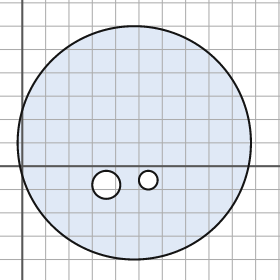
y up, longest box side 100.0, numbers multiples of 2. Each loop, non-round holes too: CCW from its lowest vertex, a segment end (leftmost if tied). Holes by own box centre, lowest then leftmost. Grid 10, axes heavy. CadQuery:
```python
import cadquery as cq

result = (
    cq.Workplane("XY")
    .moveTo(48.0, 10.0)
    .circle(50.0)
    .moveTo(36.0, -8.0)
    .circle(6.0)
    .moveTo(54.0, -6.0)
    .circle(4.0)
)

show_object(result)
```